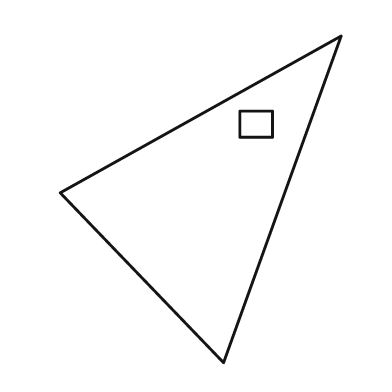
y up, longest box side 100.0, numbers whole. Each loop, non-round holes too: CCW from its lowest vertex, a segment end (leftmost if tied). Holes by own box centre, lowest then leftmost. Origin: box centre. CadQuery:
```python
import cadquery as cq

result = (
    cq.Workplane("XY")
    .moveTo(7.0, -50.0)
    .lineTo(43.0, 50.0)
    .lineTo(-43.0, 2.0)
    .close()
    .moveTo(12.0, 19.0)
    .lineTo(22.0, 19.0)
    .lineTo(22.0, 27.0)
    .lineTo(12.0, 27.0)
    .close()
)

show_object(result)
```